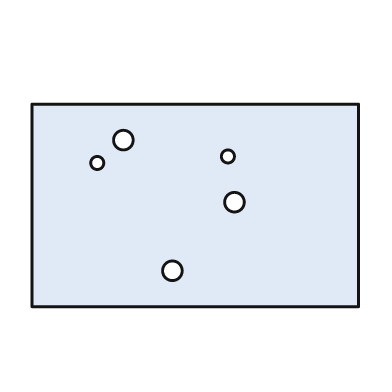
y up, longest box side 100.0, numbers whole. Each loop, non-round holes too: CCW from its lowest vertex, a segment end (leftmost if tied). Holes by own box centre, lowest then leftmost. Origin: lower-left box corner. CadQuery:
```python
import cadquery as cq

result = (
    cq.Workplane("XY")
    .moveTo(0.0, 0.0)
    .lineTo(100.0, 0.0)
    .lineTo(100.0, 62.0)
    .lineTo(0.0, 62.0)
    .close()
    .moveTo(43.0, 11.0)
    .circle(3.0)
    .moveTo(62.0, 32.0)
    .circle(3.0)
    .moveTo(20.0, 44.0)
    .circle(2.0)
    .moveTo(60.0, 46.0)
    .circle(2.0)
    .moveTo(28.0, 51.0)
    .circle(3.0)
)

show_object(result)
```